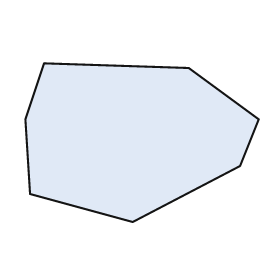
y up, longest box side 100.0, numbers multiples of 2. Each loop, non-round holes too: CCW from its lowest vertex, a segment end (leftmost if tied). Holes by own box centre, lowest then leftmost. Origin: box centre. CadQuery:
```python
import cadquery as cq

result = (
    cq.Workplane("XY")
    .moveTo(-4.0, -34.0)
    .lineTo(42.0, -10.0)
    .lineTo(50.0, 10.0)
    .lineTo(20.0, 32.0)
    .lineTo(-42.0, 34.0)
    .lineTo(-50.0, 10.0)
    .lineTo(-48.0, -22.0)
    .close()
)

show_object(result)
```